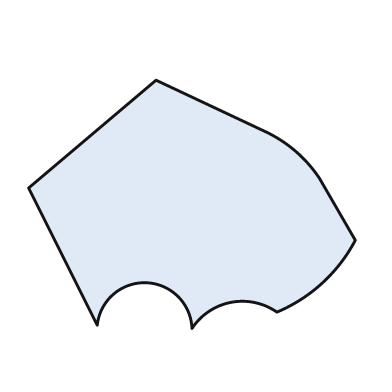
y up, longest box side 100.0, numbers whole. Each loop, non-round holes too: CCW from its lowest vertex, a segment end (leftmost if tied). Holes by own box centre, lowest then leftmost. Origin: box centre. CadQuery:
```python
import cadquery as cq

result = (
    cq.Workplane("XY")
    .moveTo(0.0, -38.0)
    .threePointArc((12.0, -30.0), (26.0, -33.0))
    .threePointArc((40.0, -24.0), (50.0, -11.0))
    .lineTo(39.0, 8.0)
    .threePointArc((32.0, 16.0), (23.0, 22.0))
    .lineTo(-11.0, 38.0)
    .lineTo(-50.0, 5.0)
    .lineTo(-29.0, -37.0)
    .threePointArc((-14.0, -24.0), (0.0, -38.0))
    .close()
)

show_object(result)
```